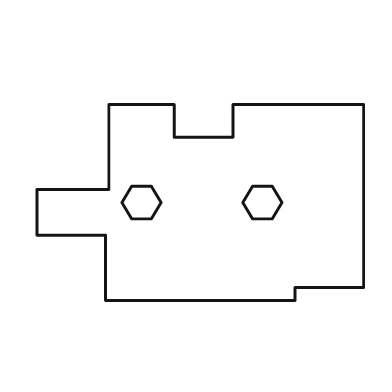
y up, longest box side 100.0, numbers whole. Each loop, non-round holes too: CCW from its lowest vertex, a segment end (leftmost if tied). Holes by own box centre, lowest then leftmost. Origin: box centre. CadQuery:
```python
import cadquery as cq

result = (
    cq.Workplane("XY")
    .moveTo(-29.0, -30.0)
    .lineTo(29.0, -30.0)
    .lineTo(29.0, -26.0)
    .lineTo(50.0, -26.0)
    .lineTo(50.0, 30.0)
    .lineTo(10.0, 30.0)
    .lineTo(10.0, 20.0)
    .lineTo(-8.0, 20.0)
    .lineTo(-8.0, 30.0)
    .lineTo(-28.0, 30.0)
    .lineTo(-28.0, 4.0)
    .lineTo(-50.0, 4.0)
    .lineTo(-50.0, -10.0)
    .lineTo(-29.0, -10.0)
    .close()
    .moveTo(-21.0, -5.0)
    .lineTo(-15.0, -5.0)
    .lineTo(-12.0, 0.0)
    .lineTo(-15.0, 5.0)
    .lineTo(-21.0, 5.0)
    .lineTo(-24.0, 0.0)
    .close()
    .moveTo(16.0, -5.0)
    .lineTo(22.0, -5.0)
    .lineTo(25.0, 0.0)
    .lineTo(22.0, 5.0)
    .lineTo(16.0, 5.0)
    .lineTo(13.0, 0.0)
    .close()
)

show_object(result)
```